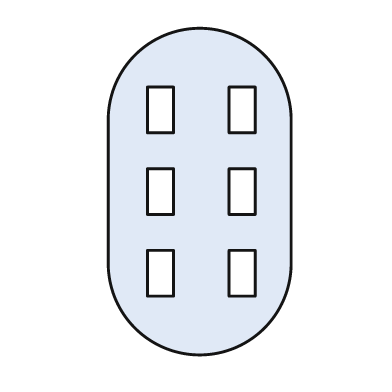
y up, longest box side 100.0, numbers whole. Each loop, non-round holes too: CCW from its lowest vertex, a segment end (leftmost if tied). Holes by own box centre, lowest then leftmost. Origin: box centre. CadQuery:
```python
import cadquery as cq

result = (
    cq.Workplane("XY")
    .moveTo(-28.0, -22.0)
    .threePointArc((0.0, -50.0), (28.0, -22.0))
    .lineTo(28.0, 22.0)
    .threePointArc((0.0, 50.0), (-28.0, 22.0))
    .close()
    .moveTo(-16.0, -32.0)
    .lineTo(-8.0, -32.0)
    .lineTo(-8.0, -18.0)
    .lineTo(-16.0, -18.0)
    .close()
    .moveTo(9.0, -32.0)
    .lineTo(17.0, -32.0)
    .lineTo(17.0, -18.0)
    .lineTo(9.0, -18.0)
    .close()
    .moveTo(-16.0, -7.0)
    .lineTo(-8.0, -7.0)
    .lineTo(-8.0, 7.0)
    .lineTo(-16.0, 7.0)
    .close()
    .moveTo(9.0, -7.0)
    .lineTo(17.0, -7.0)
    .lineTo(17.0, 7.0)
    .lineTo(9.0, 7.0)
    .close()
    .moveTo(-16.0, 18.0)
    .lineTo(-8.0, 18.0)
    .lineTo(-8.0, 32.0)
    .lineTo(-16.0, 32.0)
    .close()
    .moveTo(9.0, 18.0)
    .lineTo(17.0, 18.0)
    .lineTo(17.0, 32.0)
    .lineTo(9.0, 32.0)
    .close()
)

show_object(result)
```